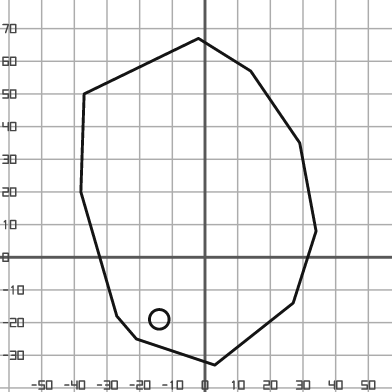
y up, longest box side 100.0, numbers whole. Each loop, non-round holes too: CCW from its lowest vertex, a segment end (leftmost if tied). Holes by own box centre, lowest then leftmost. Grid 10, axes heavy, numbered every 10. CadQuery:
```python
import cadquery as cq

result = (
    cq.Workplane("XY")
    .moveTo(3.0, -33.0)
    .lineTo(27.0, -14.0)
    .lineTo(34.0, 8.0)
    .lineTo(29.0, 35.0)
    .lineTo(14.0, 57.0)
    .lineTo(-2.0, 67.0)
    .lineTo(-37.0, 50.0)
    .lineTo(-38.0, 20.0)
    .lineTo(-27.0, -18.0)
    .lineTo(-21.0, -25.0)
    .close()
    .moveTo(-14.0, -19.0)
    .circle(3.0)
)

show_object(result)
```